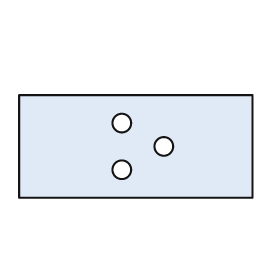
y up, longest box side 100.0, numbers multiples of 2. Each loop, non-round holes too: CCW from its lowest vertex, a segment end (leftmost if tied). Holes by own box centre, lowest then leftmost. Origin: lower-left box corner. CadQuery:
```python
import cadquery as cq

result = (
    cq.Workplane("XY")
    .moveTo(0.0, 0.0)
    .lineTo(100.0, 0.0)
    .lineTo(100.0, 44.0)
    .lineTo(0.0, 44.0)
    .close()
    .moveTo(44.0, 12.0)
    .circle(4.0)
    .moveTo(62.0, 22.0)
    .circle(4.0)
    .moveTo(44.0, 32.0)
    .circle(4.0)
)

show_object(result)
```